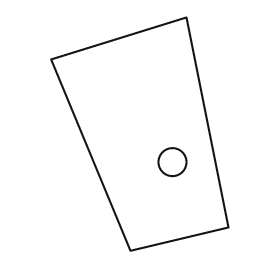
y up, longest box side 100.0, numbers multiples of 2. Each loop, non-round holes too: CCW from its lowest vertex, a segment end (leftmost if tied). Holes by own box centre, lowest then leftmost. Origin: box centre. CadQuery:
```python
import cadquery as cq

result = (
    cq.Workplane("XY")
    .moveTo(-4.0, -50.0)
    .lineTo(38.0, -40.0)
    .lineTo(20.0, 50.0)
    .lineTo(-38.0, 32.0)
    .close()
    .moveTo(14.0, -12.0)
    .circle(6.0)
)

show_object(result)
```